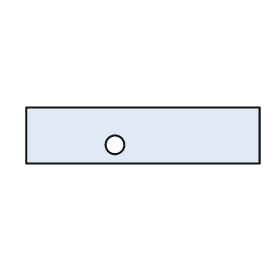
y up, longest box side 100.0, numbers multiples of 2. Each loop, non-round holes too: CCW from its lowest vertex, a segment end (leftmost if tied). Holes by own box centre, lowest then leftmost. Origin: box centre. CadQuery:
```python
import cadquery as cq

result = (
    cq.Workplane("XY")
    .moveTo(-50.0, -12.0)
    .lineTo(50.0, -12.0)
    .lineTo(50.0, 12.0)
    .lineTo(-50.0, 12.0)
    .close()
    .moveTo(-12.0, -4.0)
    .circle(4.0)
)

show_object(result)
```